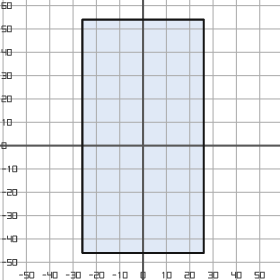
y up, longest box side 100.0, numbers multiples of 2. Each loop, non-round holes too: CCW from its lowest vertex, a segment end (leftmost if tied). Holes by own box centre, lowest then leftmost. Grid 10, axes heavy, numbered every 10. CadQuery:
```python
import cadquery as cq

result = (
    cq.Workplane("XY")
    .moveTo(-26.0, -46.0)
    .lineTo(26.0, -46.0)
    .lineTo(26.0, 54.0)
    .lineTo(-26.0, 54.0)
    .close()
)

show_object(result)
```